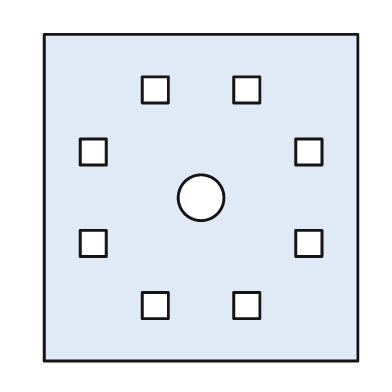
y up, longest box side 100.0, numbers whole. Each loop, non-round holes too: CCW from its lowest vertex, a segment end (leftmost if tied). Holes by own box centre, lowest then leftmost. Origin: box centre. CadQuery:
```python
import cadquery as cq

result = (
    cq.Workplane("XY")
    .moveTo(-48.0, -50.0)
    .lineTo(48.0, -50.0)
    .lineTo(48.0, 50.0)
    .lineTo(-48.0, 50.0)
    .close()
    .moveTo(-18.0, -37.0)
    .lineTo(-10.0, -37.0)
    .lineTo(-10.0, -29.0)
    .lineTo(-18.0, -29.0)
    .close()
    .moveTo(10.0, -37.0)
    .lineTo(18.0, -37.0)
    .lineTo(18.0, -29.0)
    .lineTo(10.0, -29.0)
    .close()
    .moveTo(-37.0, -18.0)
    .lineTo(-29.0, -18.0)
    .lineTo(-29.0, -10.0)
    .lineTo(-37.0, -10.0)
    .close()
    .moveTo(29.0, -18.0)
    .lineTo(37.0, -18.0)
    .lineTo(37.0, -10.0)
    .lineTo(29.0, -10.0)
    .close()
    .moveTo(0.0, 0.0)
    .circle(7.0)
    .moveTo(-37.0, 10.0)
    .lineTo(-29.0, 10.0)
    .lineTo(-29.0, 18.0)
    .lineTo(-37.0, 18.0)
    .close()
    .moveTo(29.0, 10.0)
    .lineTo(37.0, 10.0)
    .lineTo(37.0, 18.0)
    .lineTo(29.0, 18.0)
    .close()
    .moveTo(-18.0, 29.0)
    .lineTo(-10.0, 29.0)
    .lineTo(-10.0, 37.0)
    .lineTo(-18.0, 37.0)
    .close()
    .moveTo(10.0, 29.0)
    .lineTo(18.0, 29.0)
    .lineTo(18.0, 37.0)
    .lineTo(10.0, 37.0)
    .close()
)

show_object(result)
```